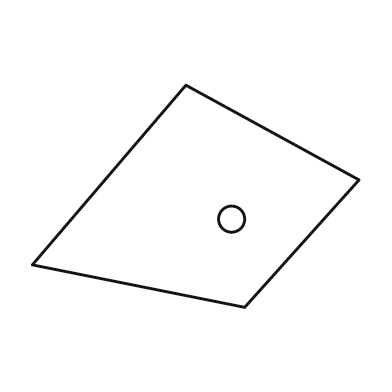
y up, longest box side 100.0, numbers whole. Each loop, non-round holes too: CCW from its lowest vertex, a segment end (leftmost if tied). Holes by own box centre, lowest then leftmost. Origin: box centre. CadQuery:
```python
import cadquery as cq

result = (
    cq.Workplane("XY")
    .moveTo(15.0, -34.0)
    .lineTo(50.0, 5.0)
    .lineTo(-3.0, 34.0)
    .lineTo(-50.0, -21.0)
    .close()
    .moveTo(11.0, -7.0)
    .circle(4.0)
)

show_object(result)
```